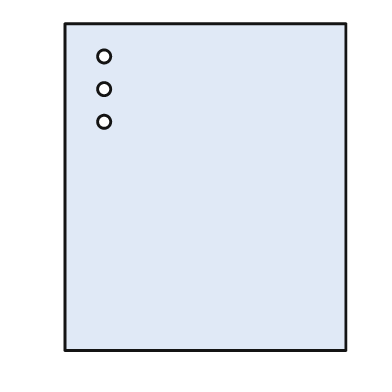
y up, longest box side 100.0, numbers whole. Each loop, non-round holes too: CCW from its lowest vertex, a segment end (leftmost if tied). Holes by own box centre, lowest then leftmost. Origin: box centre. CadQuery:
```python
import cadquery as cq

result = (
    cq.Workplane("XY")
    .moveTo(-43.0, -50.0)
    .lineTo(43.0, -50.0)
    .lineTo(43.0, 50.0)
    .lineTo(-43.0, 50.0)
    .close()
    .moveTo(-31.0, 20.0)
    .circle(2.0)
    .moveTo(-31.0, 30.0)
    .circle(2.0)
    .moveTo(-31.0, 40.0)
    .circle(2.0)
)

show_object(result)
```